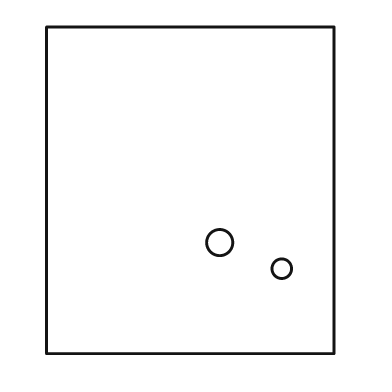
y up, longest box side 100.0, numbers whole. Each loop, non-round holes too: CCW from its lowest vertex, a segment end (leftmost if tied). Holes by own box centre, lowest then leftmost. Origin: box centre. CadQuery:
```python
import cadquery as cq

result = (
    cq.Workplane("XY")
    .moveTo(-44.0, -50.0)
    .lineTo(44.0, -50.0)
    .lineTo(44.0, 50.0)
    .lineTo(-44.0, 50.0)
    .close()
    .moveTo(28.0, -24.0)
    .circle(3.0)
    .moveTo(9.0, -16.0)
    .circle(4.0)
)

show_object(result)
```